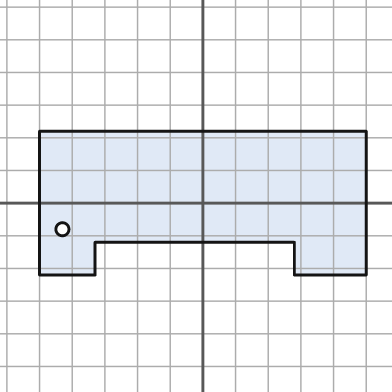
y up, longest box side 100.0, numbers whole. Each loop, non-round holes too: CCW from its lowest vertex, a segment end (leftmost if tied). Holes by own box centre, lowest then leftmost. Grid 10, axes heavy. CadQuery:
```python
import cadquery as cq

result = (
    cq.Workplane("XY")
    .moveTo(-50.0, -22.0)
    .lineTo(-33.0, -22.0)
    .lineTo(-33.0, -12.0)
    .lineTo(28.0, -12.0)
    .lineTo(28.0, -22.0)
    .lineTo(50.0, -22.0)
    .lineTo(50.0, 22.0)
    .lineTo(-50.0, 22.0)
    .close()
    .moveTo(-43.0, -8.0)
    .circle(2.0)
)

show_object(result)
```